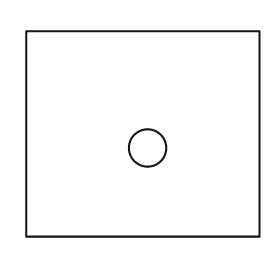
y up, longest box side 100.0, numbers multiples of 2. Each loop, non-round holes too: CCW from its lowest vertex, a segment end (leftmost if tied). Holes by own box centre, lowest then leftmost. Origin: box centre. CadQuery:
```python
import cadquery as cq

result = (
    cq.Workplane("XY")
    .moveTo(-50.0, -44.0)
    .lineTo(50.0, -44.0)
    .lineTo(50.0, 44.0)
    .lineTo(-50.0, 44.0)
    .close()
    .moveTo(2.0, -6.0)
    .circle(8.0)
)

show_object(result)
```